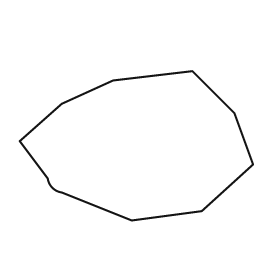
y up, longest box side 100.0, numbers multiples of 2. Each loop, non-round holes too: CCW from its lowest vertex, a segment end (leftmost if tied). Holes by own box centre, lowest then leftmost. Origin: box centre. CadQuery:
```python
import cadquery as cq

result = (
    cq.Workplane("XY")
    .moveTo(-2.0, -32.0)
    .lineTo(28.0, -28.0)
    .lineTo(50.0, -8.0)
    .lineTo(42.0, 14.0)
    .lineTo(24.0, 32.0)
    .lineTo(-10.0, 28.0)
    .lineTo(-32.0, 18.0)
    .lineTo(-50.0, 2.0)
    .lineTo(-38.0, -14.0)
    .threePointArc((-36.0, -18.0), (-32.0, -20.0))
    .close()
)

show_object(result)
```